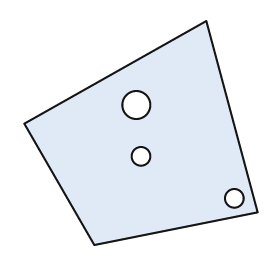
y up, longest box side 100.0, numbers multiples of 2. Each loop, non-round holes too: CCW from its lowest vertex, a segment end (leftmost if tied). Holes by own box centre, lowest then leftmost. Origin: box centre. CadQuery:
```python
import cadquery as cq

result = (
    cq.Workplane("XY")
    .moveTo(-20.0, -48.0)
    .lineTo(50.0, -34.0)
    .lineTo(28.0, 48.0)
    .lineTo(-50.0, 4.0)
    .close()
    .moveTo(40.0, -28.0)
    .circle(4.0)
    .moveTo(0.0, -10.0)
    .circle(4.0)
    .moveTo(-2.0, 12.0)
    .circle(6.0)
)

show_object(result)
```